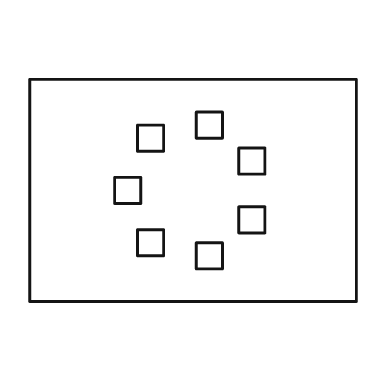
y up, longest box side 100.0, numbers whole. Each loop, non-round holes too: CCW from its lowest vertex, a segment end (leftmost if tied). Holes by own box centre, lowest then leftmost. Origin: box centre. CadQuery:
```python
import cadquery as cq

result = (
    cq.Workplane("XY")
    .moveTo(-50.0, -34.0)
    .lineTo(50.0, -34.0)
    .lineTo(50.0, 34.0)
    .lineTo(-50.0, 34.0)
    .close()
    .moveTo(1.0, -24.0)
    .lineTo(9.0, -24.0)
    .lineTo(9.0, -16.0)
    .lineTo(1.0, -16.0)
    .close()
    .moveTo(-17.0, -20.0)
    .lineTo(-9.0, -20.0)
    .lineTo(-9.0, -12.0)
    .lineTo(-17.0, -12.0)
    .close()
    .moveTo(14.0, -13.0)
    .lineTo(22.0, -13.0)
    .lineTo(22.0, -5.0)
    .lineTo(14.0, -5.0)
    .close()
    .moveTo(-24.0, -4.0)
    .lineTo(-16.0, -4.0)
    .lineTo(-16.0, 4.0)
    .lineTo(-24.0, 4.0)
    .close()
    .moveTo(14.0, 5.0)
    .lineTo(22.0, 5.0)
    .lineTo(22.0, 13.0)
    .lineTo(14.0, 13.0)
    .close()
    .moveTo(-17.0, 12.0)
    .lineTo(-9.0, 12.0)
    .lineTo(-9.0, 20.0)
    .lineTo(-17.0, 20.0)
    .close()
    .moveTo(1.0, 16.0)
    .lineTo(9.0, 16.0)
    .lineTo(9.0, 24.0)
    .lineTo(1.0, 24.0)
    .close()
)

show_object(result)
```